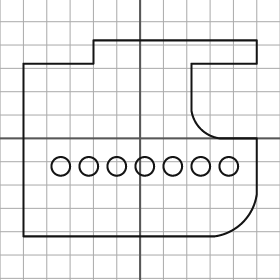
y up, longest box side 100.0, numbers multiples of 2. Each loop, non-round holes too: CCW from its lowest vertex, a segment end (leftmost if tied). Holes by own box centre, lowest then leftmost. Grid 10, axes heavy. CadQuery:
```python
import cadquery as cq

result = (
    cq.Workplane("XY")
    .moveTo(-50.0, -42.0)
    .lineTo(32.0, -42.0)
    .threePointArc((44.0, -36.0), (50.0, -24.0))
    .lineTo(50.0, 0.0)
    .lineTo(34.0, 0.0)
    .threePointArc((26.0, 4.0), (22.0, 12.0))
    .lineTo(22.0, 32.0)
    .lineTo(50.0, 32.0)
    .lineTo(50.0, 42.0)
    .lineTo(-20.0, 42.0)
    .lineTo(-20.0, 32.0)
    .lineTo(-50.0, 32.0)
    .close()
    .moveTo(-34.0, -12.0)
    .circle(4.0)
    .moveTo(-22.0, -12.0)
    .circle(4.0)
    .moveTo(-10.0, -12.0)
    .circle(4.0)
    .moveTo(2.0, -12.0)
    .circle(4.0)
    .moveTo(14.0, -12.0)
    .circle(4.0)
    .moveTo(26.0, -12.0)
    .circle(4.0)
    .moveTo(38.0, -12.0)
    .circle(4.0)
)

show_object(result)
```